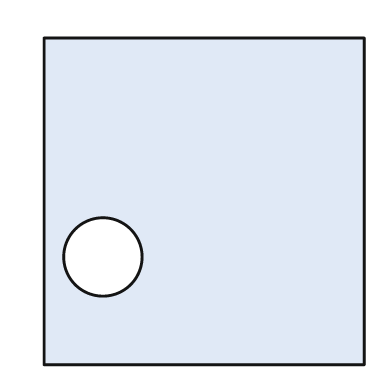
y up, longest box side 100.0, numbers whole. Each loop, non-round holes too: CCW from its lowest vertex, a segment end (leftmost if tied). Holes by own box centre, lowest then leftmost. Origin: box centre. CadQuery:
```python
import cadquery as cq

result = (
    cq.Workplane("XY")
    .moveTo(-49.0, -50.0)
    .lineTo(49.0, -50.0)
    .lineTo(49.0, 50.0)
    .lineTo(-49.0, 50.0)
    .close()
    .moveTo(-31.0, -17.0)
    .circle(12.0)
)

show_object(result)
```